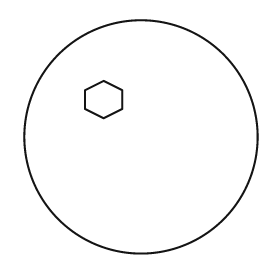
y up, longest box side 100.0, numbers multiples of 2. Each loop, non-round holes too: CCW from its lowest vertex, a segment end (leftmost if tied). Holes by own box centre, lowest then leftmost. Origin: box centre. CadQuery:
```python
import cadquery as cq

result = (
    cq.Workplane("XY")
    .moveTo(0.0, 0.0)
    .circle(50.0)
    .moveTo(-16.0, 8.0)
    .lineTo(-8.0, 12.0)
    .lineTo(-8.0, 20.0)
    .lineTo(-16.0, 24.0)
    .lineTo(-24.0, 20.0)
    .lineTo(-24.0, 12.0)
    .close()
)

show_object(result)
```